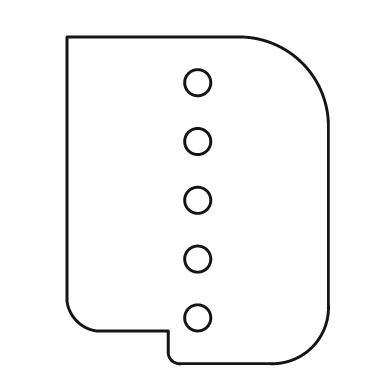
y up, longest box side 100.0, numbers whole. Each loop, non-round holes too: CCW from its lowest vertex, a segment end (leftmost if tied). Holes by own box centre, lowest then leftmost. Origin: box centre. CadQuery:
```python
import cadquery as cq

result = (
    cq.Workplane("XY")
    .moveTo(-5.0, -50.0)
    .lineTo(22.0, -50.0)
    .threePointArc((35.0, -45.0), (40.0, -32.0))
    .lineTo(40.0, 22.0)
    .threePointArc((32.0, 42.0), (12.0, 50.0))
    .lineTo(-40.0, 50.0)
    .lineTo(-40.0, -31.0)
    .threePointArc((-37.0, -37.0), (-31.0, -40.0))
    .lineTo(-9.0, -40.0)
    .lineTo(-9.0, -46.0)
    .threePointArc((-8.0, -49.0), (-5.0, -50.0))
    .close()
    .moveTo(0.0, -36.0)
    .circle(4.0)
    .moveTo(0.0, -18.0)
    .circle(4.0)
    .moveTo(0.0, 0.0)
    .circle(4.0)
    .moveTo(0.0, 18.0)
    .circle(4.0)
    .moveTo(0.0, 36.0)
    .circle(4.0)
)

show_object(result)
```